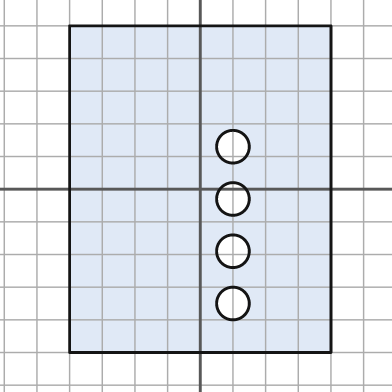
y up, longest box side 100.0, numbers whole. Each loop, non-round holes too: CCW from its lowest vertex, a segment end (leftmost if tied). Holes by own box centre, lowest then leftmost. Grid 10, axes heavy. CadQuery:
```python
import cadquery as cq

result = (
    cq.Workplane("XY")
    .moveTo(-40.0, -50.0)
    .lineTo(40.0, -50.0)
    .lineTo(40.0, 50.0)
    .lineTo(-40.0, 50.0)
    .close()
    .moveTo(10.0, -35.0)
    .circle(5.0)
    .moveTo(10.0, -19.0)
    .circle(5.0)
    .moveTo(10.0, -3.0)
    .circle(5.0)
    .moveTo(10.0, 13.0)
    .circle(5.0)
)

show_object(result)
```